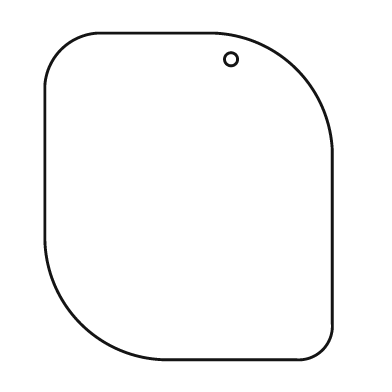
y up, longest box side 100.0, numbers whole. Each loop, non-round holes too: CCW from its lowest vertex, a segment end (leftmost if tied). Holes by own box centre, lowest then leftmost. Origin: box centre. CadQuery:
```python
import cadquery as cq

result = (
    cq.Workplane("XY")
    .moveTo(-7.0, -50.0)
    .lineTo(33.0, -50.0)
    .threePointArc((41.0, -47.0), (44.0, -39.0))
    .lineTo(44.0, 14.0)
    .threePointArc((33.0, 39.0), (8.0, 50.0))
    .lineTo(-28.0, 50.0)
    .threePointArc((-39.0, 45.0), (-44.0, 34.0))
    .lineTo(-44.0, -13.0)
    .threePointArc((-33.0, -39.0), (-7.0, -50.0))
    .close()
    .moveTo(13.0, 42.0)
    .circle(2.0)
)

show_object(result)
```